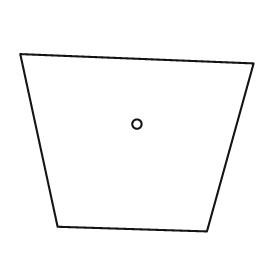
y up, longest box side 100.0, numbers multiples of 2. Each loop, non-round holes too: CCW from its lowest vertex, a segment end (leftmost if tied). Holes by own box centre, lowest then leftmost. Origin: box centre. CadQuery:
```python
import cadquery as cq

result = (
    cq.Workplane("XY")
    .moveTo(30.0, -38.0)
    .lineTo(50.0, 34.0)
    .lineTo(-50.0, 38.0)
    .lineTo(-34.0, -36.0)
    .close()
    .moveTo(0.0, 8.0)
    .circle(2.0)
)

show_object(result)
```